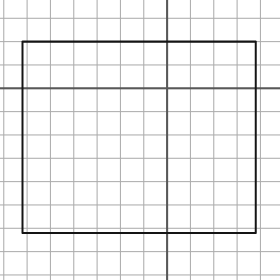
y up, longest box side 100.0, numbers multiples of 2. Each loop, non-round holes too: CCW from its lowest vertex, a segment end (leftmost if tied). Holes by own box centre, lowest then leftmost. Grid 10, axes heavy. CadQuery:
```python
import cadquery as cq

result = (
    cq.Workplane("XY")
    .moveTo(-62.0, -62.0)
    .lineTo(38.0, -62.0)
    .lineTo(38.0, 20.0)
    .lineTo(-62.0, 20.0)
    .close()
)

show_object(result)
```